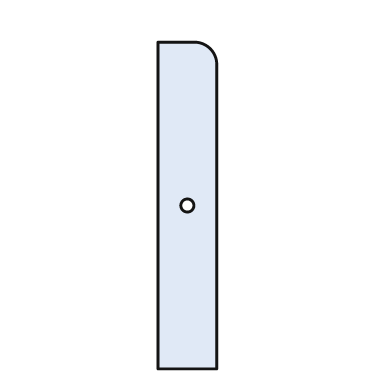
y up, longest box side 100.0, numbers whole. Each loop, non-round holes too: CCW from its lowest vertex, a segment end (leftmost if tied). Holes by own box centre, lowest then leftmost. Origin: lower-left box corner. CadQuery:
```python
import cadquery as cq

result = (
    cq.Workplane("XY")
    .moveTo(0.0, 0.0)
    .lineTo(18.0, 0.0)
    .lineTo(18.0, 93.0)
    .threePointArc((16.0, 98.0), (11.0, 100.0))
    .lineTo(0.0, 100.0)
    .close()
    .moveTo(9.0, 50.0)
    .circle(2.0)
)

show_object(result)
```